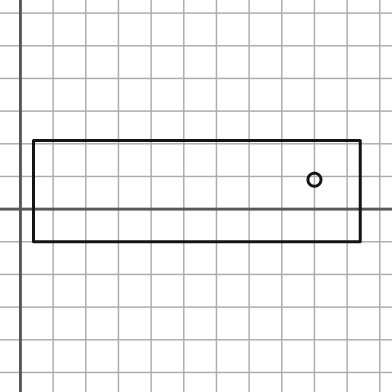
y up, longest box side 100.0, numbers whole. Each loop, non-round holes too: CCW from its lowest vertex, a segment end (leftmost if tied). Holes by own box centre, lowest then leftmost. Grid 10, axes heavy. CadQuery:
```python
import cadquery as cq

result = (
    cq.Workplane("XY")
    .moveTo(4.0, -10.0)
    .lineTo(104.0, -10.0)
    .lineTo(104.0, 21.0)
    .lineTo(4.0, 21.0)
    .close()
    .moveTo(90.0, 9.0)
    .circle(2.0)
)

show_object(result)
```